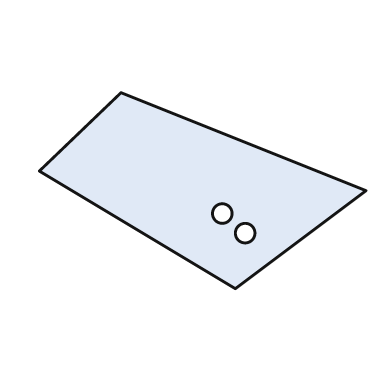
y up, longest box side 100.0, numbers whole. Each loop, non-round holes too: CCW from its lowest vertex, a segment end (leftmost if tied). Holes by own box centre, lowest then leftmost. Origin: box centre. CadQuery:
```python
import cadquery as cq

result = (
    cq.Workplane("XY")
    .moveTo(10.0, -30.0)
    .lineTo(50.0, 0.0)
    .lineTo(-25.0, 30.0)
    .lineTo(-50.0, 6.0)
    .close()
    .moveTo(13.0, -13.0)
    .circle(3.0)
    .moveTo(6.0, -7.0)
    .circle(3.0)
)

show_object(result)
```